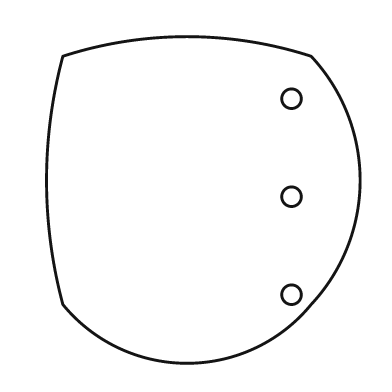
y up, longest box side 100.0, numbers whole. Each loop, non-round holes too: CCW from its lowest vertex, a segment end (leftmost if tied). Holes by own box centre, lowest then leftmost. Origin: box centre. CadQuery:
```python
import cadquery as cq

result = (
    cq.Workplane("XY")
    .moveTo(-43.0, -32.0)
    .threePointArc((-5.0, -50.0), (33.0, -32.0))
    .threePointArc((48.0, 6.0), (33.0, 44.0))
    .threePointArc((-5.0, 50.0), (-43.0, 44.0))
    .threePointArc((-48.0, 6.0), (-43.0, -32.0))
    .close()
    .moveTo(27.0, -29.0)
    .circle(3.0)
    .moveTo(27.0, 1.0)
    .circle(3.0)
    .moveTo(27.0, 31.0)
    .circle(3.0)
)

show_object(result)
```